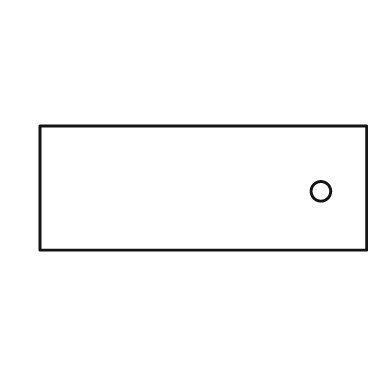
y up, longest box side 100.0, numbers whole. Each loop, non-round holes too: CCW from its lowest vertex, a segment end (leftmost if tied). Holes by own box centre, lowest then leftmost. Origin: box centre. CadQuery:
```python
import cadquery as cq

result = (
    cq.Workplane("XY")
    .moveTo(-50.0, -19.0)
    .lineTo(50.0, -19.0)
    .lineTo(50.0, 19.0)
    .lineTo(-50.0, 19.0)
    .close()
    .moveTo(36.0, -1.0)
    .circle(3.0)
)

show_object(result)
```